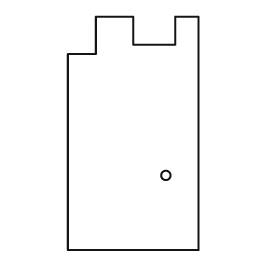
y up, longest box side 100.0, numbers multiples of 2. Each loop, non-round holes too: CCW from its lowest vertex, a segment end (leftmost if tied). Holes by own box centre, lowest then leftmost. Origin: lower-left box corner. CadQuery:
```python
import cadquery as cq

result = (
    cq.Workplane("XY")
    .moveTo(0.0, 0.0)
    .lineTo(56.0, 0.0)
    .lineTo(56.0, 100.0)
    .lineTo(46.0, 100.0)
    .lineTo(46.0, 88.0)
    .lineTo(28.0, 88.0)
    .lineTo(28.0, 100.0)
    .lineTo(12.0, 100.0)
    .lineTo(12.0, 84.0)
    .lineTo(0.0, 84.0)
    .close()
    .moveTo(42.0, 32.0)
    .circle(2.0)
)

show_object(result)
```